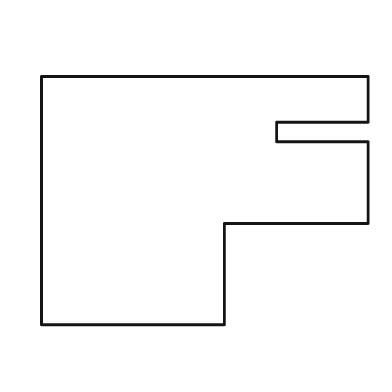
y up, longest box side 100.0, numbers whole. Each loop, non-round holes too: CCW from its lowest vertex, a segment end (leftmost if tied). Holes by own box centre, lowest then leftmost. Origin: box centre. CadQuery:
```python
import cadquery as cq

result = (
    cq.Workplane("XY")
    .moveTo(-50.0, -38.0)
    .lineTo(6.0, -38.0)
    .lineTo(6.0, -7.0)
    .lineTo(50.0, -7.0)
    .lineTo(50.0, 18.0)
    .lineTo(22.0, 18.0)
    .lineTo(22.0, 24.0)
    .lineTo(50.0, 24.0)
    .lineTo(50.0, 38.0)
    .lineTo(-50.0, 38.0)
    .close()
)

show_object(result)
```